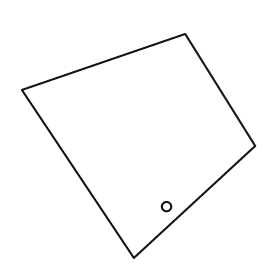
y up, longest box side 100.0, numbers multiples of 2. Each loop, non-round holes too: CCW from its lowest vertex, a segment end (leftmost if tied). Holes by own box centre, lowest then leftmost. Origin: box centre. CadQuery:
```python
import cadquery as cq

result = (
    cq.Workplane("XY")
    .moveTo(-2.0, -48.0)
    .lineTo(50.0, 0.0)
    .lineTo(20.0, 48.0)
    .lineTo(-50.0, 24.0)
    .close()
    .moveTo(12.0, -26.0)
    .circle(2.0)
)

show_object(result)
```